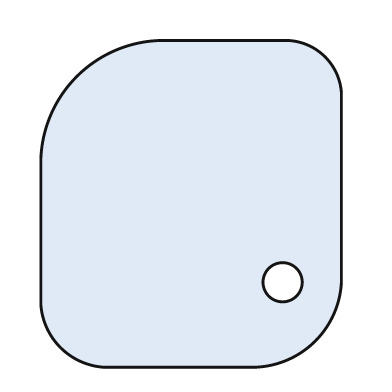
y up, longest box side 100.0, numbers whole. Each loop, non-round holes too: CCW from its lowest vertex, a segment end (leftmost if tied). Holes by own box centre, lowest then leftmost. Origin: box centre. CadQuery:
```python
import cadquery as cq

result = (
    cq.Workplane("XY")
    .moveTo(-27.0, -50.0)
    .lineTo(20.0, -50.0)
    .threePointArc((38.0, -42.0), (46.0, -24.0))
    .lineTo(46.0, 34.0)
    .threePointArc((41.0, 45.0), (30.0, 50.0))
    .lineTo(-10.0, 50.0)
    .threePointArc((-35.0, 39.0), (-46.0, 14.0))
    .lineTo(-46.0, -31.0)
    .threePointArc((-40.0, -44.0), (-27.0, -50.0))
    .close()
    .moveTo(28.0, -24.0)
    .circle(6.0)
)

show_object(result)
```